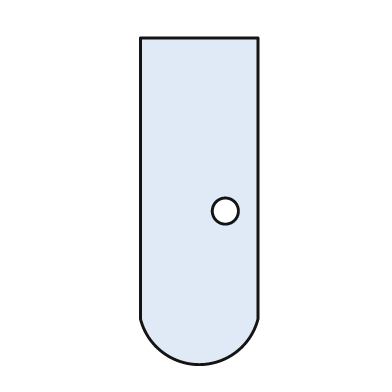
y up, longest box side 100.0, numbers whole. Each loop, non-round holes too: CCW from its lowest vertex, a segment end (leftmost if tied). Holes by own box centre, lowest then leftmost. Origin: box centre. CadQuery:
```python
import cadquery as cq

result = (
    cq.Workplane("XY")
    .moveTo(-18.0, -36.0)
    .threePointArc((0.0, -50.0), (18.0, -36.0))
    .lineTo(18.0, 50.0)
    .lineTo(-18.0, 50.0)
    .close()
    .moveTo(8.0, -3.0)
    .circle(4.0)
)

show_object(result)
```